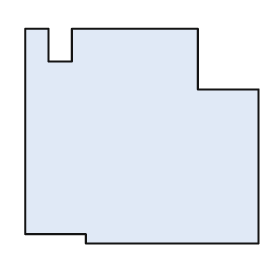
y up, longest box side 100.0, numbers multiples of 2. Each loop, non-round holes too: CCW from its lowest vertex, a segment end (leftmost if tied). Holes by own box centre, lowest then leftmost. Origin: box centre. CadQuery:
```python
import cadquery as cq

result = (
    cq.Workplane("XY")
    .moveTo(-24.0, -46.0)
    .lineTo(50.0, -46.0)
    .lineTo(50.0, 20.0)
    .lineTo(24.0, 20.0)
    .lineTo(24.0, 46.0)
    .lineTo(-30.0, 46.0)
    .lineTo(-30.0, 32.0)
    .lineTo(-40.0, 32.0)
    .lineTo(-40.0, 46.0)
    .lineTo(-50.0, 46.0)
    .lineTo(-50.0, -42.0)
    .lineTo(-24.0, -42.0)
    .close()
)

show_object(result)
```